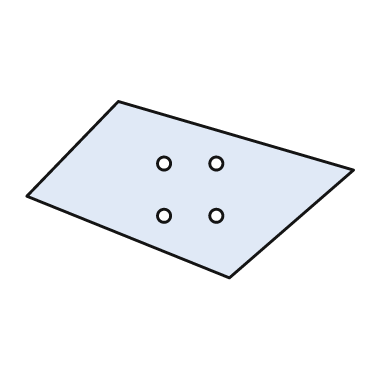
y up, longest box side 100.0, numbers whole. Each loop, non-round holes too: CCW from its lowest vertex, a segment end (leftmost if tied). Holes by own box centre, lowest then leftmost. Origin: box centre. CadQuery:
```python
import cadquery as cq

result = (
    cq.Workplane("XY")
    .moveTo(12.0, -27.0)
    .lineTo(50.0, 6.0)
    .lineTo(-22.0, 27.0)
    .lineTo(-50.0, -2.0)
    .close()
    .moveTo(-8.0, -8.0)
    .circle(2.0)
    .moveTo(8.0, -8.0)
    .circle(2.0)
    .moveTo(-8.0, 8.0)
    .circle(2.0)
    .moveTo(8.0, 8.0)
    .circle(2.0)
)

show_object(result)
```